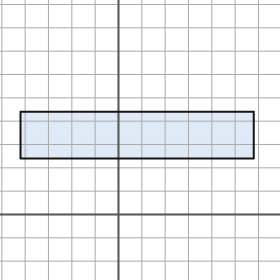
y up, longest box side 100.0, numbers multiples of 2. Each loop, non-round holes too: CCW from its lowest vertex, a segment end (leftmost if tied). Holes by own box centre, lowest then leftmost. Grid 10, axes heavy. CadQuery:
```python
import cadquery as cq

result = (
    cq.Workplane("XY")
    .moveTo(-42.0, 24.0)
    .lineTo(58.0, 24.0)
    .lineTo(58.0, 44.0)
    .lineTo(-42.0, 44.0)
    .close()
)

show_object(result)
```